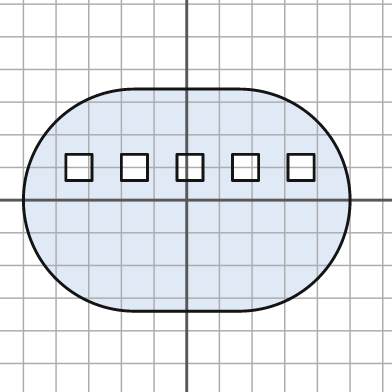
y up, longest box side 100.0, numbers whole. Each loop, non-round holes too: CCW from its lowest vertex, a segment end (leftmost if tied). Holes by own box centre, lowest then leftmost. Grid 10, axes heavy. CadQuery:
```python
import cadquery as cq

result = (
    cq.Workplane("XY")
    .moveTo(-16.0, -34.0)
    .lineTo(16.0, -34.0)
    .threePointArc((50.0, 0.0), (16.0, 34.0))
    .lineTo(-16.0, 34.0)
    .threePointArc((-50.0, 0.0), (-16.0, -34.0))
    .close()
    .moveTo(-37.0, 6.0)
    .lineTo(-29.0, 6.0)
    .lineTo(-29.0, 14.0)
    .lineTo(-37.0, 14.0)
    .close()
    .moveTo(-20.0, 6.0)
    .lineTo(-12.0, 6.0)
    .lineTo(-12.0, 14.0)
    .lineTo(-20.0, 14.0)
    .close()
    .moveTo(-3.0, 6.0)
    .lineTo(5.0, 6.0)
    .lineTo(5.0, 14.0)
    .lineTo(-3.0, 14.0)
    .close()
    .moveTo(14.0, 6.0)
    .lineTo(22.0, 6.0)
    .lineTo(22.0, 14.0)
    .lineTo(14.0, 14.0)
    .close()
    .moveTo(31.0, 6.0)
    .lineTo(39.0, 6.0)
    .lineTo(39.0, 14.0)
    .lineTo(31.0, 14.0)
    .close()
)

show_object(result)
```